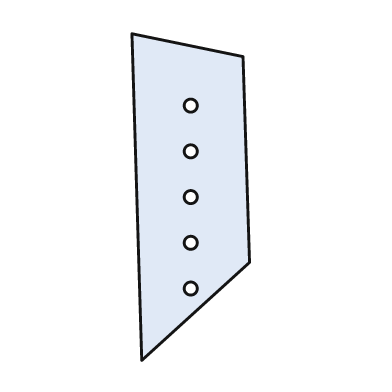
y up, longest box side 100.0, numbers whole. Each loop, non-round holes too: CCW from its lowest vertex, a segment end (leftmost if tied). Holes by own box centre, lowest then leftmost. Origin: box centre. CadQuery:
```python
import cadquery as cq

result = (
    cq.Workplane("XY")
    .moveTo(-15.0, -50.0)
    .lineTo(18.0, -20.0)
    .lineTo(16.0, 43.0)
    .lineTo(-18.0, 50.0)
    .close()
    .moveTo(0.0, -28.0)
    .circle(2.0)
    .moveTo(0.0, -14.0)
    .circle(2.0)
    .moveTo(0.0, 0.0)
    .circle(2.0)
    .moveTo(0.0, 14.0)
    .circle(2.0)
    .moveTo(0.0, 28.0)
    .circle(2.0)
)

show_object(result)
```